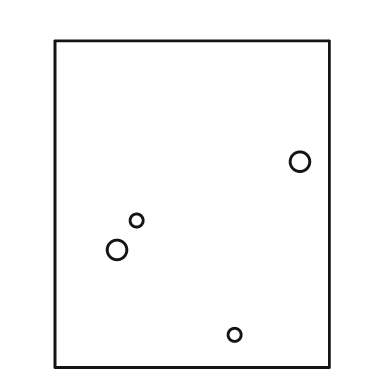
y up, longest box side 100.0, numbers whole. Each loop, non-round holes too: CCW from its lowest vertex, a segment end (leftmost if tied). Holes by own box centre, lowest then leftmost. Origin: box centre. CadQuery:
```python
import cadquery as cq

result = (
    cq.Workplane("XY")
    .moveTo(-42.0, -50.0)
    .lineTo(42.0, -50.0)
    .lineTo(42.0, 50.0)
    .lineTo(-42.0, 50.0)
    .close()
    .moveTo(13.0, -40.0)
    .circle(2.0)
    .moveTo(-23.0, -14.0)
    .circle(3.0)
    .moveTo(-17.0, -5.0)
    .circle(2.0)
    .moveTo(33.0, 13.0)
    .circle(3.0)
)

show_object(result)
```